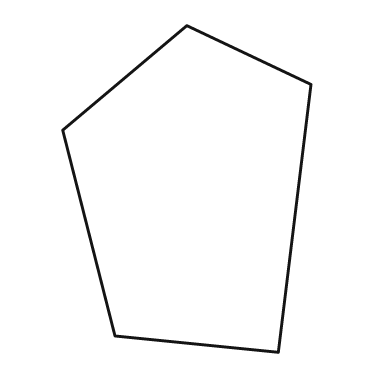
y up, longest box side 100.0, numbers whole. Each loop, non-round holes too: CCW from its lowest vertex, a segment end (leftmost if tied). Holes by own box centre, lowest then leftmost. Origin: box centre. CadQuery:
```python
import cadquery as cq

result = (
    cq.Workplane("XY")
    .moveTo(28.0, -50.0)
    .lineTo(38.0, 32.0)
    .lineTo(0.0, 50.0)
    .lineTo(-38.0, 18.0)
    .lineTo(-22.0, -45.0)
    .close()
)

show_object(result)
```